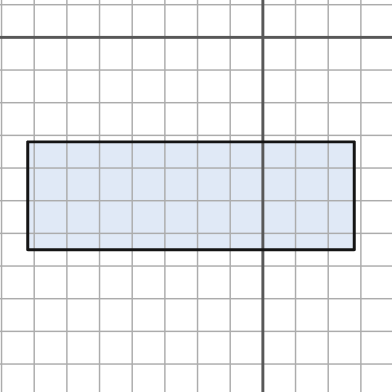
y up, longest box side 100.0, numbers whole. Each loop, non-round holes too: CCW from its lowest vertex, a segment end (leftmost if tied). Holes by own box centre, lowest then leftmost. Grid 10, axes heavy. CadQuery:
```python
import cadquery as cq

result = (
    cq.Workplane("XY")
    .moveTo(-72.0, -65.0)
    .lineTo(28.0, -65.0)
    .lineTo(28.0, -32.0)
    .lineTo(-72.0, -32.0)
    .close()
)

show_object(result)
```